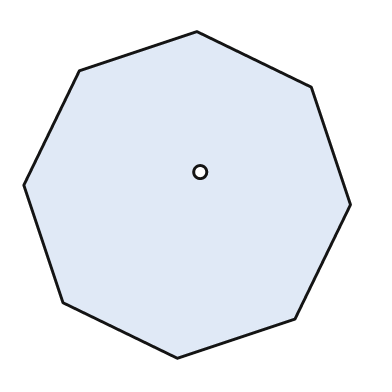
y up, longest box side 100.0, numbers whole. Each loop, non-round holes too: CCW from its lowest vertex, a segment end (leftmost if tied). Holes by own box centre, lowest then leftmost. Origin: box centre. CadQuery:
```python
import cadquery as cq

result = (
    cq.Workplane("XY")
    .moveTo(-3.0, -50.0)
    .lineTo(33.0, -38.0)
    .lineTo(50.0, -3.0)
    .lineTo(38.0, 33.0)
    .lineTo(3.0, 50.0)
    .lineTo(-33.0, 38.0)
    .lineTo(-50.0, 3.0)
    .lineTo(-38.0, -33.0)
    .close()
    .moveTo(4.0, 7.0)
    .circle(2.0)
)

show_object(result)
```